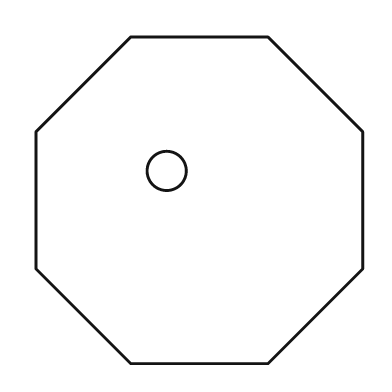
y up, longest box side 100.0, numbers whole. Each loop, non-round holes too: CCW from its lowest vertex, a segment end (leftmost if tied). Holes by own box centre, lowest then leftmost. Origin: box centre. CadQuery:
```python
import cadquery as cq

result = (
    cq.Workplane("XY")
    .moveTo(-21.0, -50.0)
    .lineTo(21.0, -50.0)
    .lineTo(50.0, -21.0)
    .lineTo(50.0, 21.0)
    .lineTo(21.0, 50.0)
    .lineTo(-21.0, 50.0)
    .lineTo(-50.0, 21.0)
    .lineTo(-50.0, -21.0)
    .close()
    .moveTo(-10.0, 9.0)
    .circle(6.0)
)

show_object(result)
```